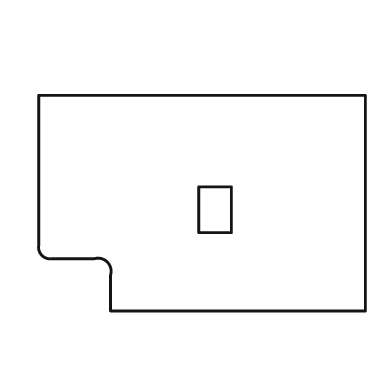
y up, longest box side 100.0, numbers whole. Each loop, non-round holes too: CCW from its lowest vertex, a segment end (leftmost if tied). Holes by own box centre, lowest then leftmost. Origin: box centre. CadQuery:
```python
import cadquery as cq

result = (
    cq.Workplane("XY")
    .moveTo(-28.0, -33.0)
    .lineTo(50.0, -33.0)
    .lineTo(50.0, 33.0)
    .lineTo(-50.0, 33.0)
    .lineTo(-50.0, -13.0)
    .threePointArc((-49.0, -16.0), (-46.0, -17.0))
    .lineTo(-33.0, -17.0)
    .threePointArc((-29.0, -18.0), (-28.0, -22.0))
    .close()
    .moveTo(-1.0, -9.0)
    .lineTo(9.0, -9.0)
    .lineTo(9.0, 5.0)
    .lineTo(-1.0, 5.0)
    .close()
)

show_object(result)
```